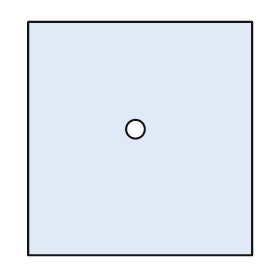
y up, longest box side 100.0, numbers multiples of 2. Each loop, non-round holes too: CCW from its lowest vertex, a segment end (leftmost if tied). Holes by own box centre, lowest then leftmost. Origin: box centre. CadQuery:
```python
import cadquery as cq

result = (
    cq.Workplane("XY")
    .moveTo(-48.0, -50.0)
    .lineTo(48.0, -50.0)
    .lineTo(48.0, 50.0)
    .lineTo(-48.0, 50.0)
    .close()
    .moveTo(-2.0, 4.0)
    .circle(4.0)
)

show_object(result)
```